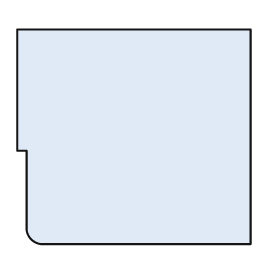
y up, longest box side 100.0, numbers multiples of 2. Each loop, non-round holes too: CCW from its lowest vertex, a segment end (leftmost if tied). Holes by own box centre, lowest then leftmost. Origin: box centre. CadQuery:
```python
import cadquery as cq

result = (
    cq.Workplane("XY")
    .moveTo(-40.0, -46.0)
    .lineTo(50.0, -46.0)
    .lineTo(50.0, 46.0)
    .lineTo(-50.0, 46.0)
    .lineTo(-50.0, -6.0)
    .lineTo(-46.0, -6.0)
    .lineTo(-46.0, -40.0)
    .threePointArc((-44.0, -44.0), (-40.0, -46.0))
    .close()
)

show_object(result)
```